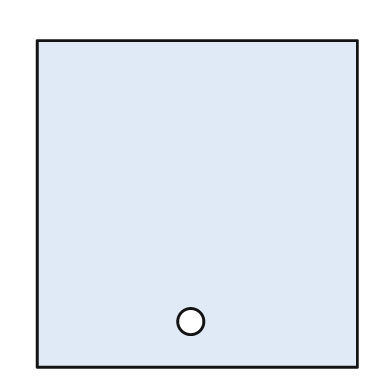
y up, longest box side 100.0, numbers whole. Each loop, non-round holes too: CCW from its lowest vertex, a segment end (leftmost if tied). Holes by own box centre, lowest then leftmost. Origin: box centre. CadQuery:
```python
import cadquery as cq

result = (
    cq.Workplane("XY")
    .moveTo(-49.0, -50.0)
    .lineTo(49.0, -50.0)
    .lineTo(49.0, 50.0)
    .lineTo(-49.0, 50.0)
    .close()
    .moveTo(-2.0, -36.0)
    .circle(4.0)
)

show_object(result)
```